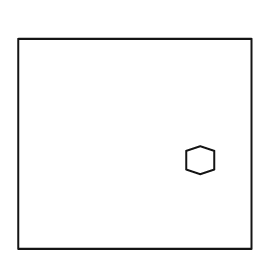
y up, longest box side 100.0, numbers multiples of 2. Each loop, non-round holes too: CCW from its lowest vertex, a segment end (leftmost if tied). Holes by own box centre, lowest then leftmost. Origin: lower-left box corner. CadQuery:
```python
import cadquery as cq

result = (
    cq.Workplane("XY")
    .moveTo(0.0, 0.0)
    .lineTo(100.0, 0.0)
    .lineTo(100.0, 90.0)
    .lineTo(0.0, 90.0)
    .close()
    .moveTo(78.0, 32.0)
    .lineTo(84.0, 34.0)
    .lineTo(84.0, 42.0)
    .lineTo(78.0, 44.0)
    .lineTo(72.0, 42.0)
    .lineTo(72.0, 34.0)
    .close()
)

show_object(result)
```